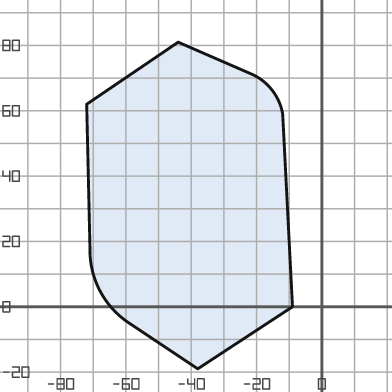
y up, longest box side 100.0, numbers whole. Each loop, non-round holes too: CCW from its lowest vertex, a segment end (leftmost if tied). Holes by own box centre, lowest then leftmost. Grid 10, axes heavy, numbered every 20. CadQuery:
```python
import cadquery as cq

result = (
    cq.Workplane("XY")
    .moveTo(-38.0, -19.0)
    .lineTo(-9.0, 0.0)
    .lineTo(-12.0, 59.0)
    .threePointArc((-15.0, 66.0), (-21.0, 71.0))
    .lineTo(-44.0, 81.0)
    .lineTo(-72.0, 62.0)
    .lineTo(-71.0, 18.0)
    .threePointArc((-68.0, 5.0), (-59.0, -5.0))
    .close()
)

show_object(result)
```